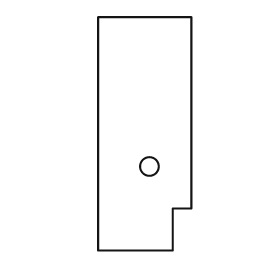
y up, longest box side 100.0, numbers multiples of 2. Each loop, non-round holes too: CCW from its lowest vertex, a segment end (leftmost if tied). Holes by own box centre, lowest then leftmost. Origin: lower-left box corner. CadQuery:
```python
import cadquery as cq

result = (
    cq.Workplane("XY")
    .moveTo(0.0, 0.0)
    .lineTo(32.0, 0.0)
    .lineTo(32.0, 18.0)
    .lineTo(40.0, 18.0)
    .lineTo(40.0, 100.0)
    .lineTo(0.0, 100.0)
    .close()
    .moveTo(22.0, 36.0)
    .circle(4.0)
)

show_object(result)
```